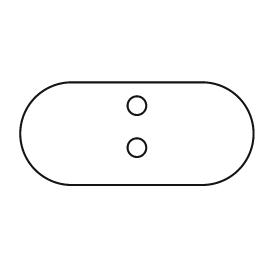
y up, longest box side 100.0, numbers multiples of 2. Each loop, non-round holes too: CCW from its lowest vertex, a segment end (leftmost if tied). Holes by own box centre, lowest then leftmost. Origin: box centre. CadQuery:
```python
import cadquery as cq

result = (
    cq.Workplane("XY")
    .moveTo(-28.0, -22.0)
    .lineTo(28.0, -22.0)
    .threePointArc((50.0, 0.0), (28.0, 22.0))
    .lineTo(-28.0, 22.0)
    .threePointArc((-50.0, 0.0), (-28.0, -22.0))
    .close()
    .moveTo(0.0, -6.0)
    .circle(4.0)
    .moveTo(0.0, 12.0)
    .circle(4.0)
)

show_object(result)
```